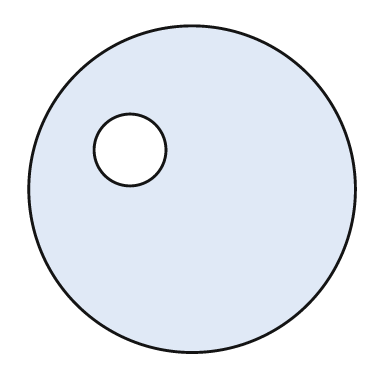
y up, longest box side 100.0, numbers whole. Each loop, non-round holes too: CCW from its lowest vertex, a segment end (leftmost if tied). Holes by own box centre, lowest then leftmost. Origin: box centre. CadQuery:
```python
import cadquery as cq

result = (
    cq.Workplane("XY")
    .moveTo(0.0, 0.0)
    .circle(50.0)
    .moveTo(-19.0, 12.0)
    .circle(11.0)
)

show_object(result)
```